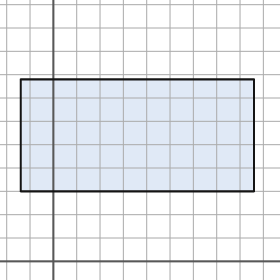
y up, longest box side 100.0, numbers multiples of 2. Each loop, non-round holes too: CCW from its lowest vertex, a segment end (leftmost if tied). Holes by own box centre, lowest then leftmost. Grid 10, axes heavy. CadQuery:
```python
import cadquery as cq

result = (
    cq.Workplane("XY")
    .moveTo(-14.0, 30.0)
    .lineTo(86.0, 30.0)
    .lineTo(86.0, 78.0)
    .lineTo(-14.0, 78.0)
    .close()
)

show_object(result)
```